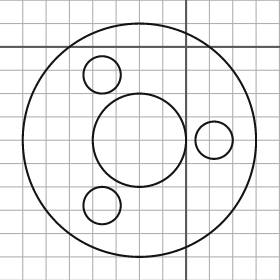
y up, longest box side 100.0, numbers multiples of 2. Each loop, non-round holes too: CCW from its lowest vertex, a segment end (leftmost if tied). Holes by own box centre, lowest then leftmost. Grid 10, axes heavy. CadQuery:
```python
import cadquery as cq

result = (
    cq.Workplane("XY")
    .moveTo(-20.0, -40.0)
    .circle(50.0)
    .moveTo(-36.0, -68.0)
    .circle(8.0)
    .moveTo(-20.0, -40.0)
    .circle(20.0)
    .moveTo(12.0, -40.0)
    .circle(8.0)
    .moveTo(-36.0, -12.0)
    .circle(8.0)
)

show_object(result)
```